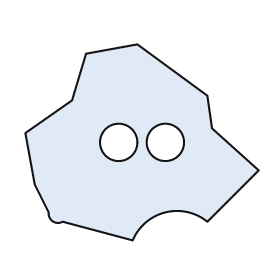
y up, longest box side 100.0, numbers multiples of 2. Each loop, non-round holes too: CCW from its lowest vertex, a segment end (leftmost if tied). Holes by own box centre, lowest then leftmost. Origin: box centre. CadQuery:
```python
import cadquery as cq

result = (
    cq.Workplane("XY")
    .moveTo(-4.0, -42.0)
    .threePointArc((10.0, -30.0), (28.0, -34.0))
    .lineTo(50.0, -12.0)
    .lineTo(30.0, 6.0)
    .lineTo(28.0, 20.0)
    .lineTo(-2.0, 42.0)
    .lineTo(-24.0, 38.0)
    .lineTo(-30.0, 18.0)
    .lineTo(-50.0, 4.0)
    .lineTo(-46.0, -18.0)
    .lineTo(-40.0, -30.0)
    .threePointArc((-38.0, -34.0), (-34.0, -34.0))
    .close()
    .moveTo(-10.0, 0.0)
    .circle(8.0)
    .moveTo(10.0, 0.0)
    .circle(8.0)
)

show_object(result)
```